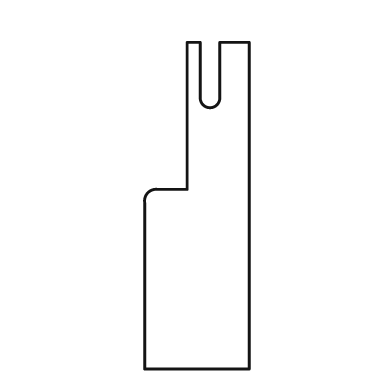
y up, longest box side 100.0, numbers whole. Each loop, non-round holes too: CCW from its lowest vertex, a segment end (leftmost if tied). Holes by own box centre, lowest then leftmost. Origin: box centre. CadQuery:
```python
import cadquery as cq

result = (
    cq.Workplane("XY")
    .moveTo(-16.0, -50.0)
    .lineTo(16.0, -50.0)
    .lineTo(16.0, 50.0)
    .lineTo(7.0, 50.0)
    .lineTo(7.0, 33.0)
    .threePointArc((4.0, 30.0), (1.0, 33.0))
    .lineTo(1.0, 50.0)
    .lineTo(-3.0, 50.0)
    .lineTo(-3.0, 5.0)
    .lineTo(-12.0, 5.0)
    .threePointArc((-15.0, 4.0), (-16.0, 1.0))
    .close()
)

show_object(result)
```